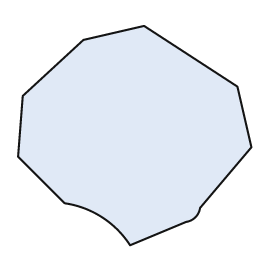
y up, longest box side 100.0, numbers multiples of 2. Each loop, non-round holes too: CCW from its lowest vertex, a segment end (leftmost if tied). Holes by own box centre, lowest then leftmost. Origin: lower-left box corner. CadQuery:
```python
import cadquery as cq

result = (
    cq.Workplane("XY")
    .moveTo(48.0, 0.0)
    .lineTo(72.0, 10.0)
    .threePointArc((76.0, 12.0), (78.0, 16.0))
    .lineTo(100.0, 42.0)
    .lineTo(94.0, 68.0)
    .lineTo(54.0, 94.0)
    .lineTo(28.0, 88.0)
    .lineTo(2.0, 64.0)
    .lineTo(0.0, 38.0)
    .lineTo(20.0, 18.0)
    .threePointArc((36.0, 12.0), (48.0, 0.0))
    .close()
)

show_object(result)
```